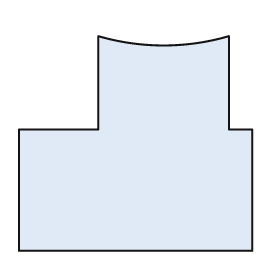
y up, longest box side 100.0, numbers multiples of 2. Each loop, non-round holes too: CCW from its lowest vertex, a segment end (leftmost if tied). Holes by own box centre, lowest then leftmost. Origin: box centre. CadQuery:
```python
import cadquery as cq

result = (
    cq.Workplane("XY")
    .moveTo(-50.0, -46.0)
    .lineTo(50.0, -46.0)
    .lineTo(50.0, 6.0)
    .lineTo(40.0, 6.0)
    .lineTo(40.0, 46.0)
    .threePointArc((12.0, 42.0), (-16.0, 46.0))
    .lineTo(-16.0, 6.0)
    .lineTo(-50.0, 6.0)
    .close()
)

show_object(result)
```